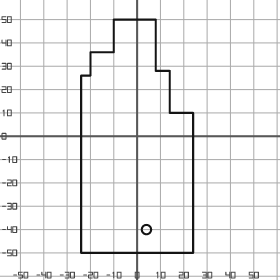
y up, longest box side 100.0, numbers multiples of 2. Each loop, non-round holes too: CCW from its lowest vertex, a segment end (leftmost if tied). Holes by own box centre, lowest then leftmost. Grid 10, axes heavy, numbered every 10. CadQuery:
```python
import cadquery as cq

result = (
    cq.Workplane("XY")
    .moveTo(-24.0, -50.0)
    .lineTo(24.0, -50.0)
    .lineTo(24.0, 10.0)
    .lineTo(14.0, 10.0)
    .lineTo(14.0, 28.0)
    .lineTo(8.0, 28.0)
    .lineTo(8.0, 50.0)
    .lineTo(-10.0, 50.0)
    .lineTo(-10.0, 36.0)
    .lineTo(-20.0, 36.0)
    .lineTo(-20.0, 26.0)
    .lineTo(-24.0, 26.0)
    .close()
    .moveTo(4.0, -40.0)
    .circle(2.0)
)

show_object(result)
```